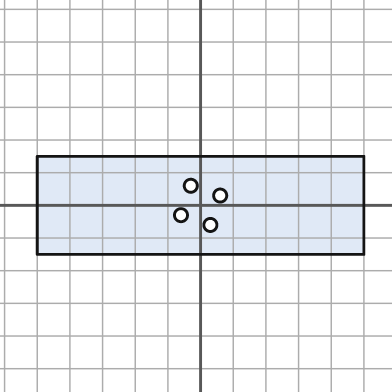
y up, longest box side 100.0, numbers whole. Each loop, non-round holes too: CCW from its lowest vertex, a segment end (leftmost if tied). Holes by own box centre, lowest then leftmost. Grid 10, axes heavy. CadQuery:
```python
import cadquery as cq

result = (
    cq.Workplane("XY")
    .moveTo(-50.0, -15.0)
    .lineTo(50.0, -15.0)
    .lineTo(50.0, 15.0)
    .lineTo(-50.0, 15.0)
    .close()
    .moveTo(3.0, -6.0)
    .circle(2.0)
    .moveTo(-6.0, -3.0)
    .circle(2.0)
    .moveTo(6.0, 3.0)
    .circle(2.0)
    .moveTo(-3.0, 6.0)
    .circle(2.0)
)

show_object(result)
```